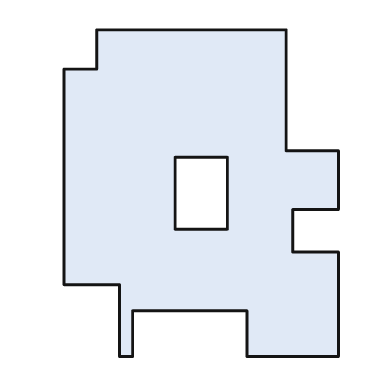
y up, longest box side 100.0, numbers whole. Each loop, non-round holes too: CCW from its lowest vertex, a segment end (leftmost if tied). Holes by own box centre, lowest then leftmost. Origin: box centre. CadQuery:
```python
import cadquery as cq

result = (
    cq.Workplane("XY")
    .moveTo(-25.0, -50.0)
    .lineTo(-21.0, -50.0)
    .lineTo(-21.0, -36.0)
    .lineTo(14.0, -36.0)
    .lineTo(14.0, -50.0)
    .lineTo(42.0, -50.0)
    .lineTo(42.0, -18.0)
    .lineTo(28.0, -18.0)
    .lineTo(28.0, -5.0)
    .lineTo(42.0, -5.0)
    .lineTo(42.0, 13.0)
    .lineTo(26.0, 13.0)
    .lineTo(26.0, 50.0)
    .lineTo(-32.0, 50.0)
    .lineTo(-32.0, 38.0)
    .lineTo(-42.0, 38.0)
    .lineTo(-42.0, -28.0)
    .lineTo(-25.0, -28.0)
    .close()
    .moveTo(-8.0, -11.0)
    .lineTo(8.0, -11.0)
    .lineTo(8.0, 11.0)
    .lineTo(-8.0, 11.0)
    .close()
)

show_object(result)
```